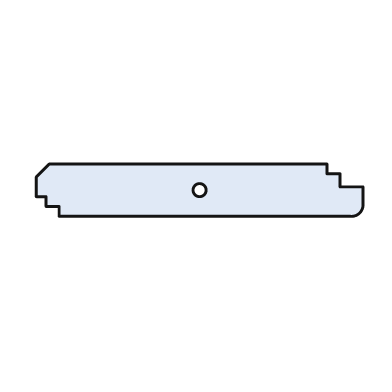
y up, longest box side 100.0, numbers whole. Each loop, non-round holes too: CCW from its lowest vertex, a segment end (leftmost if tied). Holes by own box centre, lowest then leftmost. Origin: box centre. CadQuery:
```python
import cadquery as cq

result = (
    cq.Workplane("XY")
    .moveTo(-43.0, -8.0)
    .lineTo(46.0, -8.0)
    .threePointArc((49.0, -7.0), (50.0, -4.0))
    .lineTo(50.0, 1.0)
    .lineTo(43.0, 1.0)
    .lineTo(43.0, 5.0)
    .lineTo(39.0, 5.0)
    .lineTo(39.0, 8.0)
    .lineTo(-46.0, 8.0)
    .lineTo(-50.0, 4.0)
    .lineTo(-50.0, -2.0)
    .lineTo(-47.0, -2.0)
    .lineTo(-47.0, -5.0)
    .lineTo(-43.0, -5.0)
    .close()
    .moveTo(0.0, 0.0)
    .circle(2.0)
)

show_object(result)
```